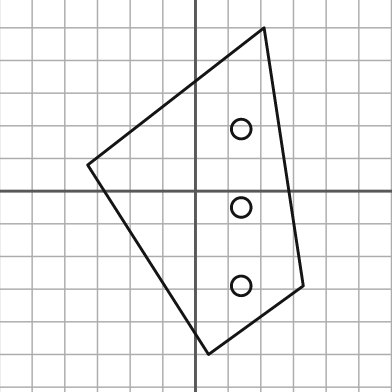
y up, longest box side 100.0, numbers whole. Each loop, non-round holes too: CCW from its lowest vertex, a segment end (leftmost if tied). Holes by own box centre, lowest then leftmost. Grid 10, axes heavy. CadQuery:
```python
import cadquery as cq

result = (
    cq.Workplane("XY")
    .moveTo(4.0, -50.0)
    .lineTo(33.0, -29.0)
    .lineTo(21.0, 50.0)
    .lineTo(-33.0, 8.0)
    .close()
    .moveTo(14.0, -29.0)
    .circle(3.0)
    .moveTo(14.0, -5.0)
    .circle(3.0)
    .moveTo(14.0, 19.0)
    .circle(3.0)
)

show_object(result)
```